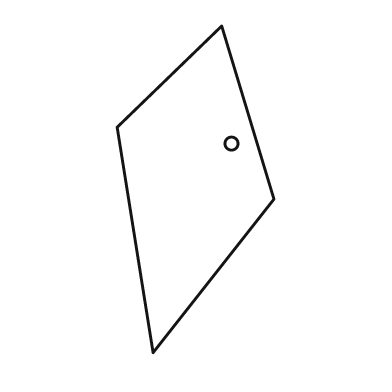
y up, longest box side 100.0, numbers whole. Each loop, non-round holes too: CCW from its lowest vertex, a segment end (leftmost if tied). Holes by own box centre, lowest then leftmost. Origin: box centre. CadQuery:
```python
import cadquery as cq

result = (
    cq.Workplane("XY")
    .moveTo(-13.0, -50.0)
    .lineTo(24.0, -3.0)
    .lineTo(8.0, 50.0)
    .lineTo(-24.0, 19.0)
    .close()
    .moveTo(11.0, 14.0)
    .circle(2.0)
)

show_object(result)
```